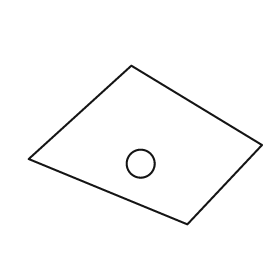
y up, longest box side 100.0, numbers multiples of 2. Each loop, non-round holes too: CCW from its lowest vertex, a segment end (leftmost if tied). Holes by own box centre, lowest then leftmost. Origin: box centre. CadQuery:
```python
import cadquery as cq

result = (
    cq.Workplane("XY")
    .moveTo(18.0, -34.0)
    .lineTo(50.0, 0.0)
    .lineTo(-6.0, 34.0)
    .lineTo(-50.0, -6.0)
    .close()
    .moveTo(-2.0, -8.0)
    .circle(6.0)
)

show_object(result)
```